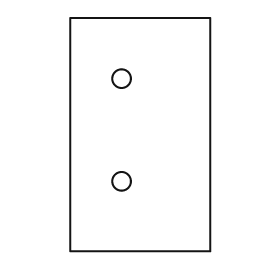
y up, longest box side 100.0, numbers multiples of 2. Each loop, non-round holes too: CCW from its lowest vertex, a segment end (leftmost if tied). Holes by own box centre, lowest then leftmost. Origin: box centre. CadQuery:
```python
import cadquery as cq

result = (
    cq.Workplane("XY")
    .moveTo(-30.0, -50.0)
    .lineTo(30.0, -50.0)
    .lineTo(30.0, 50.0)
    .lineTo(-30.0, 50.0)
    .close()
    .moveTo(-8.0, -20.0)
    .circle(4.0)
    .moveTo(-8.0, 24.0)
    .circle(4.0)
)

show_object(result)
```